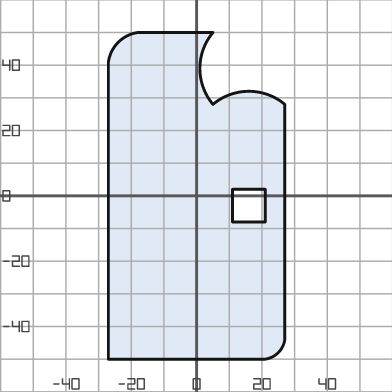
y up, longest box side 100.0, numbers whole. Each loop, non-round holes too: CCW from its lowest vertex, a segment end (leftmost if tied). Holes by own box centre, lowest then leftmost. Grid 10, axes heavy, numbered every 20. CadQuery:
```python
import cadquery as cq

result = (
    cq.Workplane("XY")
    .moveTo(-27.0, -50.0)
    .lineTo(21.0, -50.0)
    .threePointArc((25.0, -48.0), (27.0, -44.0))
    .lineTo(27.0, 28.0)
    .threePointArc((16.0, 32.0), (5.0, 28.0))
    .threePointArc((1.0, 39.0), (5.0, 50.0))
    .lineTo(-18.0, 50.0)
    .threePointArc((-24.0, 47.0), (-27.0, 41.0))
    .close()
    .moveTo(11.0, -8.0)
    .lineTo(21.0, -8.0)
    .lineTo(21.0, 2.0)
    .lineTo(11.0, 2.0)
    .close()
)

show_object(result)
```